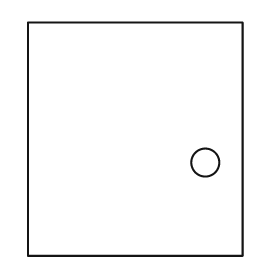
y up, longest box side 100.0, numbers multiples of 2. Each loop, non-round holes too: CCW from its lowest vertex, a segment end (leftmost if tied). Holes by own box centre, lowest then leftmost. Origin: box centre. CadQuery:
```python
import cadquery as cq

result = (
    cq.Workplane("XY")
    .moveTo(-46.0, -50.0)
    .lineTo(46.0, -50.0)
    .lineTo(46.0, 50.0)
    .lineTo(-46.0, 50.0)
    .close()
    .moveTo(30.0, -10.0)
    .circle(6.0)
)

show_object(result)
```